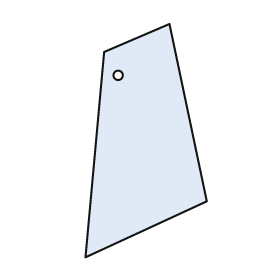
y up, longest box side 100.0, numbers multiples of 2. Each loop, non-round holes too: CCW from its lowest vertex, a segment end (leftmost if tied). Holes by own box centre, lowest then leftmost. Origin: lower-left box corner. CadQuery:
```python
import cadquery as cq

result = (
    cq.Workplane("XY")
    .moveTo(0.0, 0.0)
    .lineTo(52.0, 24.0)
    .lineTo(36.0, 100.0)
    .lineTo(8.0, 88.0)
    .close()
    .moveTo(14.0, 78.0)
    .circle(2.0)
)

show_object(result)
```